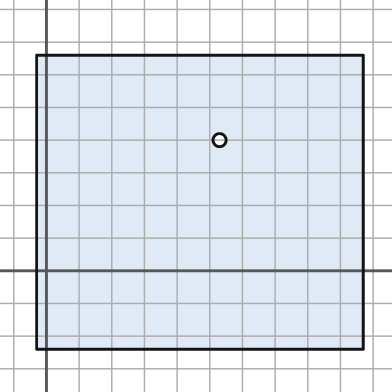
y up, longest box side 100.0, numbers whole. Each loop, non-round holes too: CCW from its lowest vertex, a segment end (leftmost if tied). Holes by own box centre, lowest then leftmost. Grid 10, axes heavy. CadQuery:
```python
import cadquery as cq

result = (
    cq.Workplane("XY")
    .moveTo(-3.0, -24.0)
    .lineTo(97.0, -24.0)
    .lineTo(97.0, 66.0)
    .lineTo(-3.0, 66.0)
    .close()
    .moveTo(53.0, 40.0)
    .circle(2.0)
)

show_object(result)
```